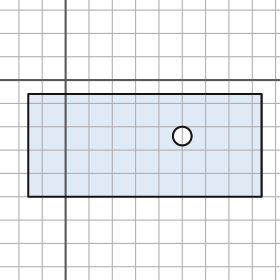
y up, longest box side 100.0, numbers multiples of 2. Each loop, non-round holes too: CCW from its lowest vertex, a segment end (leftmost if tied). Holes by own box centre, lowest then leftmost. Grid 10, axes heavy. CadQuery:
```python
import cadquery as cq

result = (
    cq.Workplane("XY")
    .moveTo(-16.0, -50.0)
    .lineTo(84.0, -50.0)
    .lineTo(84.0, -6.0)
    .lineTo(-16.0, -6.0)
    .close()
    .moveTo(50.0, -24.0)
    .circle(4.0)
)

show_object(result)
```